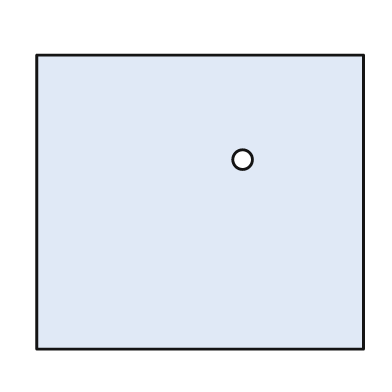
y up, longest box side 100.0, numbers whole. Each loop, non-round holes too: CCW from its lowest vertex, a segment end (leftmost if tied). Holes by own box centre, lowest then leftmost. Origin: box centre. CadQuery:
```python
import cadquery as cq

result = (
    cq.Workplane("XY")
    .moveTo(-50.0, -45.0)
    .lineTo(50.0, -45.0)
    .lineTo(50.0, 45.0)
    .lineTo(-50.0, 45.0)
    .close()
    .moveTo(13.0, 13.0)
    .circle(3.0)
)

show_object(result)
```